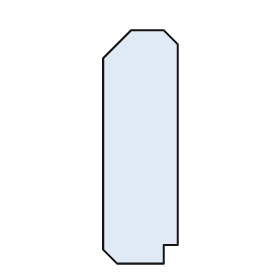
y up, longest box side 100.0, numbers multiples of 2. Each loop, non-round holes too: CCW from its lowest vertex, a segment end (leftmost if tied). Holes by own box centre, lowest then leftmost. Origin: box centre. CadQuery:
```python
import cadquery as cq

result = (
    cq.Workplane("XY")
    .moveTo(-10.0, -50.0)
    .lineTo(10.0, -50.0)
    .lineTo(10.0, -42.0)
    .lineTo(16.0, -42.0)
    .lineTo(16.0, 44.0)
    .lineTo(10.0, 50.0)
    .lineTo(-4.0, 50.0)
    .lineTo(-16.0, 38.0)
    .lineTo(-16.0, -44.0)
    .close()
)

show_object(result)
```